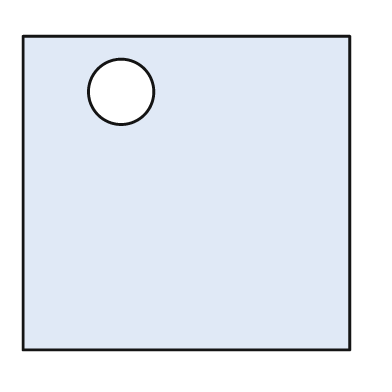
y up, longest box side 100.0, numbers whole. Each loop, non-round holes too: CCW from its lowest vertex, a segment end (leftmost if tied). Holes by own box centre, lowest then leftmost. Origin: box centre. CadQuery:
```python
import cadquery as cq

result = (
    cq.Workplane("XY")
    .moveTo(-50.0, -48.0)
    .lineTo(50.0, -48.0)
    .lineTo(50.0, 48.0)
    .lineTo(-50.0, 48.0)
    .close()
    .moveTo(-20.0, 31.0)
    .circle(10.0)
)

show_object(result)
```